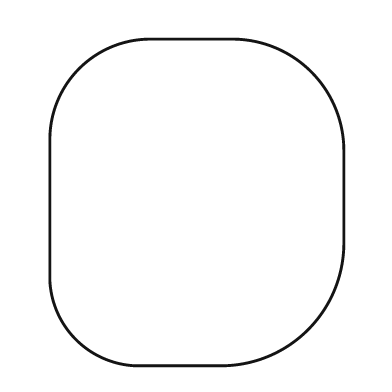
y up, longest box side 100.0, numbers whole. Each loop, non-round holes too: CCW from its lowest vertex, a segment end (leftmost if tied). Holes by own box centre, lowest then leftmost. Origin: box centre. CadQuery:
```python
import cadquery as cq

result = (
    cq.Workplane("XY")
    .moveTo(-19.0, -50.0)
    .lineTo(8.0, -50.0)
    .threePointArc((34.0, -39.0), (45.0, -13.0))
    .lineTo(45.0, 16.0)
    .threePointArc((35.0, 40.0), (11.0, 50.0))
    .lineTo(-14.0, 50.0)
    .threePointArc((-36.0, 41.0), (-45.0, 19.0))
    .lineTo(-45.0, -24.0)
    .threePointArc((-37.0, -42.0), (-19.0, -50.0))
    .close()
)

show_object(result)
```